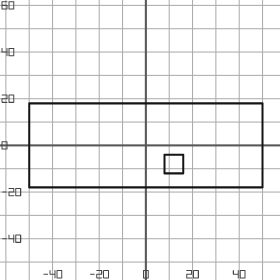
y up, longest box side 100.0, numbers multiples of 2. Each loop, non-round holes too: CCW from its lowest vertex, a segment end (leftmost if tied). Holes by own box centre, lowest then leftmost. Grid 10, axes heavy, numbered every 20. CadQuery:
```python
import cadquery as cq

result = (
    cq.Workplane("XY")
    .moveTo(-50.0, -18.0)
    .lineTo(50.0, -18.0)
    .lineTo(50.0, 18.0)
    .lineTo(-50.0, 18.0)
    .close()
    .moveTo(8.0, -12.0)
    .lineTo(16.0, -12.0)
    .lineTo(16.0, -4.0)
    .lineTo(8.0, -4.0)
    .close()
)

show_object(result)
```